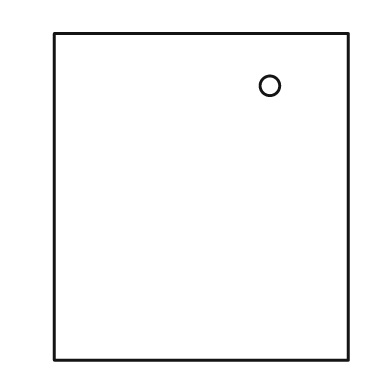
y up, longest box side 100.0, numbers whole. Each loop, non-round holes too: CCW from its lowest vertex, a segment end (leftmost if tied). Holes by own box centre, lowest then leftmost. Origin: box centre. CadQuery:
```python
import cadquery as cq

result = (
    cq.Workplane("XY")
    .moveTo(-45.0, -50.0)
    .lineTo(45.0, -50.0)
    .lineTo(45.0, 50.0)
    .lineTo(-45.0, 50.0)
    .close()
    .moveTo(21.0, 34.0)
    .circle(3.0)
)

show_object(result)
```